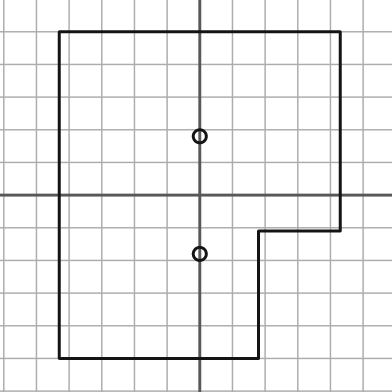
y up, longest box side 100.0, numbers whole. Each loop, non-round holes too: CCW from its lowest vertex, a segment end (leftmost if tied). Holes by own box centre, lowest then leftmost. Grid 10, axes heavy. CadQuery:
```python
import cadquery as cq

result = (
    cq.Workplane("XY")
    .moveTo(-43.0, -50.0)
    .lineTo(18.0, -50.0)
    .lineTo(18.0, -11.0)
    .lineTo(43.0, -11.0)
    .lineTo(43.0, 50.0)
    .lineTo(-43.0, 50.0)
    .close()
    .moveTo(0.0, -18.0)
    .circle(2.0)
    .moveTo(0.0, 18.0)
    .circle(2.0)
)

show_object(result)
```